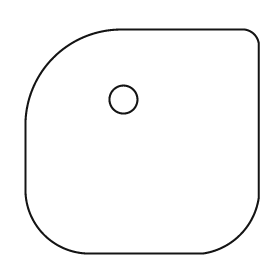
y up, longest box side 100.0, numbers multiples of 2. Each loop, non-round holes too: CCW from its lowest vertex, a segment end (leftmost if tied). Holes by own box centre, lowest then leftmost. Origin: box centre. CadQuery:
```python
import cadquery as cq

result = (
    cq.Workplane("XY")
    .moveTo(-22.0, -48.0)
    .lineTo(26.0, -48.0)
    .threePointArc((42.0, -40.0), (50.0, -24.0))
    .lineTo(50.0, 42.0)
    .threePointArc((48.0, 46.0), (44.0, 48.0))
    .lineTo(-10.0, 48.0)
    .threePointArc((-38.0, 36.0), (-50.0, 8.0))
    .lineTo(-50.0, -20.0)
    .threePointArc((-42.0, -40.0), (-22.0, -48.0))
    .close()
    .moveTo(-8.0, 18.0)
    .circle(6.0)
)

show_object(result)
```